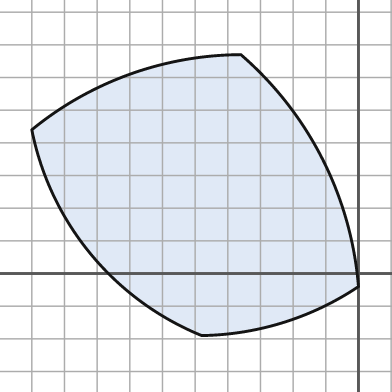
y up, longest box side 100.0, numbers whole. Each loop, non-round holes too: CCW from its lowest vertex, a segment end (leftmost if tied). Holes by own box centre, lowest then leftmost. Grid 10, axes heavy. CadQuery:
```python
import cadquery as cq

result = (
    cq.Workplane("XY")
    .moveTo(-48.0, -19.0)
    .threePointArc((-23.0, -15.0), (0.0, -4.0))
    .threePointArc((-11.0, 35.0), (-36.0, 67.0))
    .threePointArc((-70.0, 61.0), (-100.0, 44.0))
    .threePointArc((-82.0, 6.0), (-48.0, -19.0))
    .close()
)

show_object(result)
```